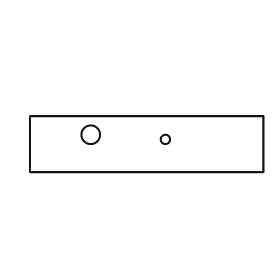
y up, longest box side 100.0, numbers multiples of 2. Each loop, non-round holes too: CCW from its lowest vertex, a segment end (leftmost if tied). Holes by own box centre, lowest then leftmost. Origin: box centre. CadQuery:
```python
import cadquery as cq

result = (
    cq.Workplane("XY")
    .moveTo(-50.0, -12.0)
    .lineTo(50.0, -12.0)
    .lineTo(50.0, 12.0)
    .lineTo(-50.0, 12.0)
    .close()
    .moveTo(8.0, 2.0)
    .circle(2.0)
    .moveTo(-24.0, 4.0)
    .circle(4.0)
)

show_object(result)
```